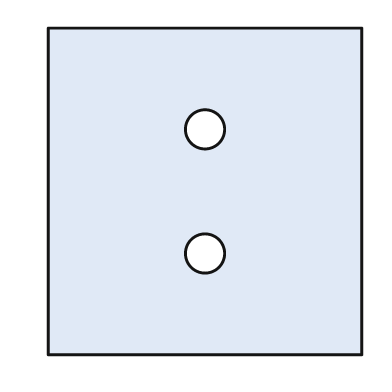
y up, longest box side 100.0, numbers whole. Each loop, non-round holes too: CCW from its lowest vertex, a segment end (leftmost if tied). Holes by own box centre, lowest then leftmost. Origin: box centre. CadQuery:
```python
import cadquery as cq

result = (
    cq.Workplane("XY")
    .moveTo(-48.0, -50.0)
    .lineTo(48.0, -50.0)
    .lineTo(48.0, 50.0)
    .lineTo(-48.0, 50.0)
    .close()
    .moveTo(0.0, -19.0)
    .circle(6.0)
    .moveTo(0.0, 19.0)
    .circle(6.0)
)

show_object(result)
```